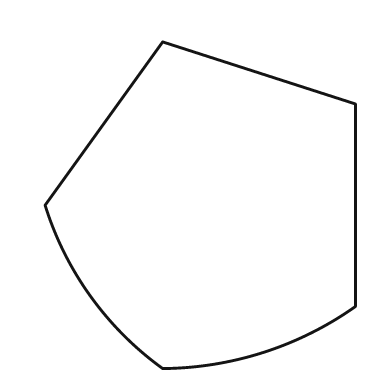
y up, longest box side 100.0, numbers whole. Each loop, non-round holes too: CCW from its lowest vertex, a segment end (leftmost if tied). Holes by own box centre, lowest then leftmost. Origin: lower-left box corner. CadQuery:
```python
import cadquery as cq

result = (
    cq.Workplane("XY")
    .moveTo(36.0, 0.0)
    .threePointArc((67.0, 5.0), (95.0, 19.0))
    .lineTo(95.0, 81.0)
    .lineTo(36.0, 100.0)
    .lineTo(0.0, 50.0)
    .threePointArc((14.0, 22.0), (36.0, 0.0))
    .close()
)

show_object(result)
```